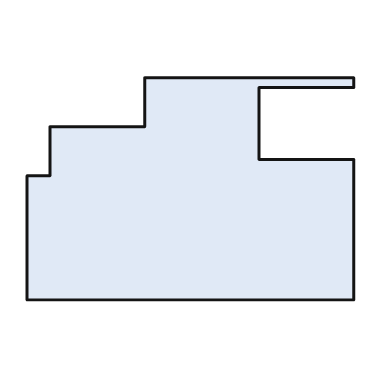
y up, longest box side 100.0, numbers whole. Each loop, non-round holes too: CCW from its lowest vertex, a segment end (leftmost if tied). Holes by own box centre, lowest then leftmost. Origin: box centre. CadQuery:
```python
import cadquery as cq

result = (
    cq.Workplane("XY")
    .moveTo(-50.0, -34.0)
    .lineTo(50.0, -34.0)
    .lineTo(50.0, 9.0)
    .lineTo(21.0, 9.0)
    .lineTo(21.0, 31.0)
    .lineTo(50.0, 31.0)
    .lineTo(50.0, 34.0)
    .lineTo(-14.0, 34.0)
    .lineTo(-14.0, 19.0)
    .lineTo(-43.0, 19.0)
    .lineTo(-43.0, 4.0)
    .lineTo(-50.0, 4.0)
    .close()
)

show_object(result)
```